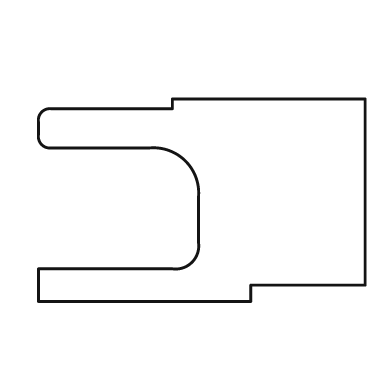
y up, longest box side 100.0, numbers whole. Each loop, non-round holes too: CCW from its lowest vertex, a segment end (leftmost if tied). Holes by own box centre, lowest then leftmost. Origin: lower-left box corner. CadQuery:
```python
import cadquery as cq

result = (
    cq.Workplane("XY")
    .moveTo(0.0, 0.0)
    .lineTo(65.0, 0.0)
    .lineTo(65.0, 5.0)
    .lineTo(100.0, 5.0)
    .lineTo(100.0, 62.0)
    .lineTo(41.0, 62.0)
    .lineTo(41.0, 59.0)
    .lineTo(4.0, 59.0)
    .threePointArc((1.0, 58.0), (0.0, 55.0))
    .lineTo(0.0, 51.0)
    .threePointArc((1.0, 48.0), (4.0, 47.0))
    .lineTo(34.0, 47.0)
    .threePointArc((45.0, 43.0), (49.0, 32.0))
    .lineTo(49.0, 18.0)
    .threePointArc((47.0, 12.0), (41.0, 10.0))
    .lineTo(0.0, 10.0)
    .close()
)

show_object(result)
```